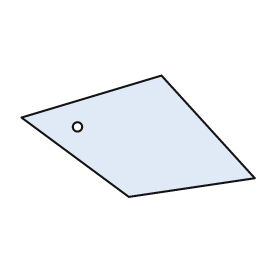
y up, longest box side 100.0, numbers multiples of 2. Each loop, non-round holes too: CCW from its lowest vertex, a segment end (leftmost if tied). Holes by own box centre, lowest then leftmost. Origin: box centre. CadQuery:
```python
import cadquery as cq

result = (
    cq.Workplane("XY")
    .moveTo(-4.0, -26.0)
    .lineTo(50.0, -18.0)
    .lineTo(10.0, 26.0)
    .lineTo(-50.0, 8.0)
    .close()
    .moveTo(-26.0, 4.0)
    .circle(2.0)
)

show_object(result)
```